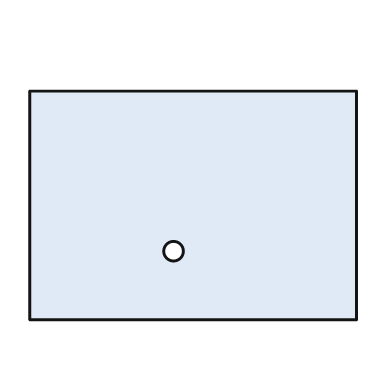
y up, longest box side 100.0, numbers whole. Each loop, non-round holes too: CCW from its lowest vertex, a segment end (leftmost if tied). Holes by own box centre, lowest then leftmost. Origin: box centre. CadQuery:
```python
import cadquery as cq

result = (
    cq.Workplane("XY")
    .moveTo(-50.0, -35.0)
    .lineTo(50.0, -35.0)
    .lineTo(50.0, 35.0)
    .lineTo(-50.0, 35.0)
    .close()
    .moveTo(-6.0, -14.0)
    .circle(3.0)
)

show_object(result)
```